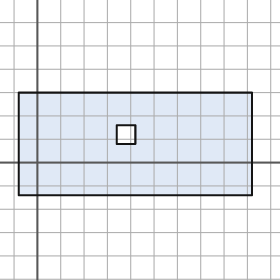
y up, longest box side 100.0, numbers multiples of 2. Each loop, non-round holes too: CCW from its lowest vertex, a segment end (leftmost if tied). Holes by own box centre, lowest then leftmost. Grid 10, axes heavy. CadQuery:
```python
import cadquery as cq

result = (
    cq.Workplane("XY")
    .moveTo(-8.0, -14.0)
    .lineTo(92.0, -14.0)
    .lineTo(92.0, 30.0)
    .lineTo(-8.0, 30.0)
    .close()
    .moveTo(34.0, 8.0)
    .lineTo(42.0, 8.0)
    .lineTo(42.0, 16.0)
    .lineTo(34.0, 16.0)
    .close()
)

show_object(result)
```